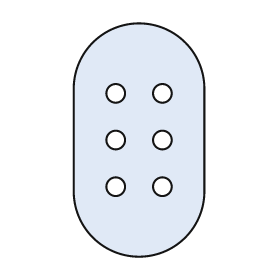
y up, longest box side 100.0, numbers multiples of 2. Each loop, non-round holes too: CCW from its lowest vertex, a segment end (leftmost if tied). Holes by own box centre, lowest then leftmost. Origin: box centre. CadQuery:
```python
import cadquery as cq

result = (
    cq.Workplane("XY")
    .moveTo(-28.0, -22.0)
    .threePointArc((0.0, -50.0), (28.0, -22.0))
    .lineTo(28.0, 22.0)
    .threePointArc((0.0, 50.0), (-28.0, 22.0))
    .close()
    .moveTo(-10.0, -20.0)
    .circle(4.0)
    .moveTo(10.0, -20.0)
    .circle(4.0)
    .moveTo(-10.0, 0.0)
    .circle(4.0)
    .moveTo(10.0, 0.0)
    .circle(4.0)
    .moveTo(-10.0, 20.0)
    .circle(4.0)
    .moveTo(10.0, 20.0)
    .circle(4.0)
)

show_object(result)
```